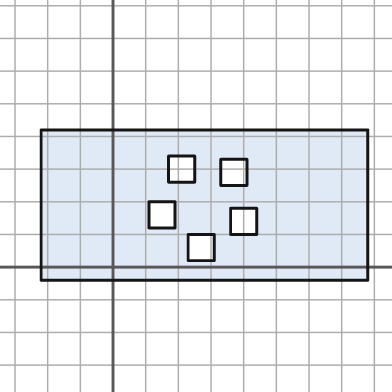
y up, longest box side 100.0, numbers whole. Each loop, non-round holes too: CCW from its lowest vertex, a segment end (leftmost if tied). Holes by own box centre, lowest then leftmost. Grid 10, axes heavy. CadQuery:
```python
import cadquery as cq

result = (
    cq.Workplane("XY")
    .moveTo(-22.0, -4.0)
    .lineTo(78.0, -4.0)
    .lineTo(78.0, 42.0)
    .lineTo(-22.0, 42.0)
    .close()
    .moveTo(23.0, 2.0)
    .lineTo(31.0, 2.0)
    .lineTo(31.0, 10.0)
    .lineTo(23.0, 10.0)
    .close()
    .moveTo(36.0, 10.0)
    .lineTo(44.0, 10.0)
    .lineTo(44.0, 18.0)
    .lineTo(36.0, 18.0)
    .close()
    .moveTo(11.0, 12.0)
    .lineTo(19.0, 12.0)
    .lineTo(19.0, 20.0)
    .lineTo(11.0, 20.0)
    .close()
    .moveTo(33.0, 25.0)
    .lineTo(41.0, 25.0)
    .lineTo(41.0, 33.0)
    .lineTo(33.0, 33.0)
    .close()
    .moveTo(17.0, 26.0)
    .lineTo(25.0, 26.0)
    .lineTo(25.0, 34.0)
    .lineTo(17.0, 34.0)
    .close()
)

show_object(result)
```